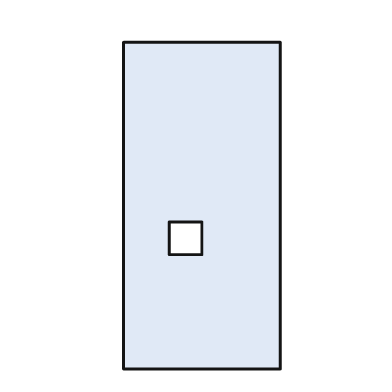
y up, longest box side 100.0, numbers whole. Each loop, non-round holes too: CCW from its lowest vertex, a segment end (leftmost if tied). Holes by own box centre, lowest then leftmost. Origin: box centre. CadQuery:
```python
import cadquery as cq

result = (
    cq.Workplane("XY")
    .moveTo(-24.0, -50.0)
    .lineTo(24.0, -50.0)
    .lineTo(24.0, 50.0)
    .lineTo(-24.0, 50.0)
    .close()
    .moveTo(-10.0, -15.0)
    .lineTo(0.0, -15.0)
    .lineTo(0.0, -5.0)
    .lineTo(-10.0, -5.0)
    .close()
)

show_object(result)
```